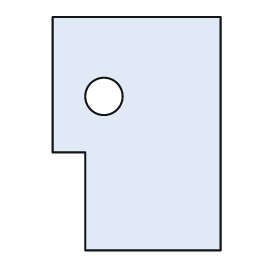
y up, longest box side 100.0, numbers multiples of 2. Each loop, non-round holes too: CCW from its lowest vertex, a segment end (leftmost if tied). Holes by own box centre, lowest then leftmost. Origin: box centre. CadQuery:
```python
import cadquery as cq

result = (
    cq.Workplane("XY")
    .moveTo(-22.0, -50.0)
    .lineTo(36.0, -50.0)
    .lineTo(36.0, 50.0)
    .lineTo(-36.0, 50.0)
    .lineTo(-36.0, -8.0)
    .lineTo(-22.0, -8.0)
    .close()
    .moveTo(-14.0, 16.0)
    .circle(8.0)
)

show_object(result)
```